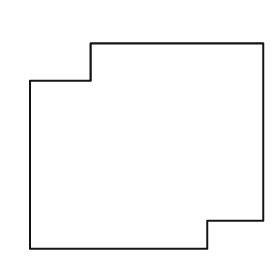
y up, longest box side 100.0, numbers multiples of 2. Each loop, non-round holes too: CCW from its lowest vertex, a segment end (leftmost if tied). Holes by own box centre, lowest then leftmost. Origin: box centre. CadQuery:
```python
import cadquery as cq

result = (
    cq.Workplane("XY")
    .moveTo(-50.0, -44.0)
    .lineTo(26.0, -44.0)
    .lineTo(26.0, -32.0)
    .lineTo(50.0, -32.0)
    .lineTo(50.0, 44.0)
    .lineTo(-24.0, 44.0)
    .lineTo(-24.0, 28.0)
    .lineTo(-50.0, 28.0)
    .close()
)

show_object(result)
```